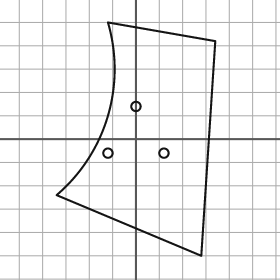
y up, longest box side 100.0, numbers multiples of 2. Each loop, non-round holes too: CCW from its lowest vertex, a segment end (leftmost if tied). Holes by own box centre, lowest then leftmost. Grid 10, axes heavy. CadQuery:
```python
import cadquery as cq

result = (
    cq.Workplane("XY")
    .moveTo(28.0, -50.0)
    .lineTo(34.0, 42.0)
    .lineTo(-12.0, 50.0)
    .threePointArc((-12.0, 10.0), (-34.0, -24.0))
    .close()
    .moveTo(-12.0, -6.0)
    .circle(2.0)
    .moveTo(12.0, -6.0)
    .circle(2.0)
    .moveTo(0.0, 14.0)
    .circle(2.0)
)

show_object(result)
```